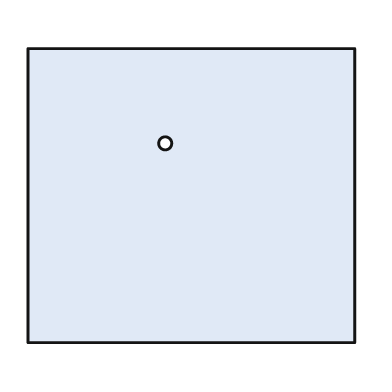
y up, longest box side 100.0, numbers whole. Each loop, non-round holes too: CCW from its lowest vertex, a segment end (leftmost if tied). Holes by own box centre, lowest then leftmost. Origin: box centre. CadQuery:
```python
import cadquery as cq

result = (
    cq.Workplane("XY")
    .moveTo(-50.0, -45.0)
    .lineTo(50.0, -45.0)
    .lineTo(50.0, 45.0)
    .lineTo(-50.0, 45.0)
    .close()
    .moveTo(-8.0, 16.0)
    .circle(2.0)
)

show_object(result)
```